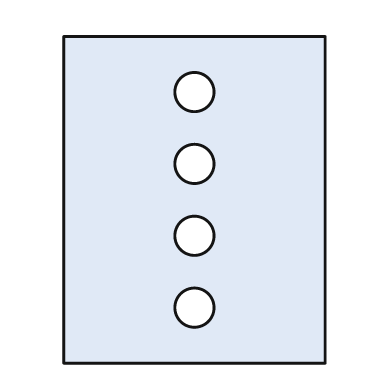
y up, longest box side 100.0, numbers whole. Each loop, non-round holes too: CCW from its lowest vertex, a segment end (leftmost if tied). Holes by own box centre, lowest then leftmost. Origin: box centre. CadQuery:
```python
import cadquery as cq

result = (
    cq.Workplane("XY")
    .moveTo(-40.0, -50.0)
    .lineTo(40.0, -50.0)
    .lineTo(40.0, 50.0)
    .lineTo(-40.0, 50.0)
    .close()
    .moveTo(0.0, -33.0)
    .circle(6.0)
    .moveTo(0.0, -11.0)
    .circle(6.0)
    .moveTo(0.0, 11.0)
    .circle(6.0)
    .moveTo(0.0, 33.0)
    .circle(6.0)
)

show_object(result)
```